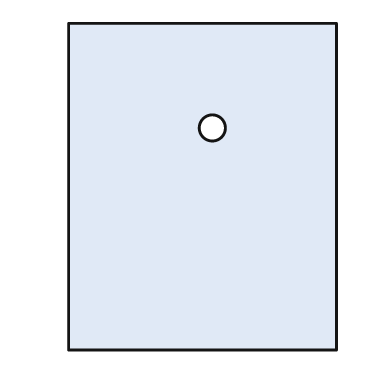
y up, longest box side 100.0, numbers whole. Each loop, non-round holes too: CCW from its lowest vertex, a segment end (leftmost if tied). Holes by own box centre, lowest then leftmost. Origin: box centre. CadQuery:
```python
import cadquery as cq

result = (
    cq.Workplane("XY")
    .moveTo(-41.0, -50.0)
    .lineTo(41.0, -50.0)
    .lineTo(41.0, 50.0)
    .lineTo(-41.0, 50.0)
    .close()
    .moveTo(3.0, 18.0)
    .circle(4.0)
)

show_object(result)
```